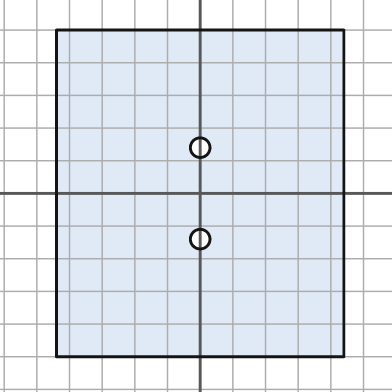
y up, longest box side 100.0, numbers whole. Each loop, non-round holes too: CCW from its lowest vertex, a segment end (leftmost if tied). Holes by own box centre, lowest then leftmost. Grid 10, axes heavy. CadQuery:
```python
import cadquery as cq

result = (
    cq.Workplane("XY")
    .moveTo(-44.0, -50.0)
    .lineTo(44.0, -50.0)
    .lineTo(44.0, 50.0)
    .lineTo(-44.0, 50.0)
    .close()
    .moveTo(0.0, -14.0)
    .circle(3.0)
    .moveTo(0.0, 14.0)
    .circle(3.0)
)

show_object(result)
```